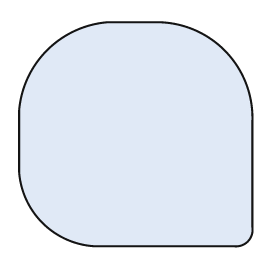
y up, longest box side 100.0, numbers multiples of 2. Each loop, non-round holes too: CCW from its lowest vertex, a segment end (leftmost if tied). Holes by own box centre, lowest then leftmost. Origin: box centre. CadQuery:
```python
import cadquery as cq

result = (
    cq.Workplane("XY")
    .moveTo(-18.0, -48.0)
    .lineTo(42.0, -48.0)
    .threePointArc((48.0, -46.0), (50.0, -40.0))
    .lineTo(50.0, 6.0)
    .threePointArc((38.0, 36.0), (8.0, 48.0))
    .lineTo(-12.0, 48.0)
    .threePointArc((-38.0, 36.0), (-50.0, 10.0))
    .lineTo(-50.0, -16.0)
    .threePointArc((-40.0, -38.0), (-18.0, -48.0))
    .close()
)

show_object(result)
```